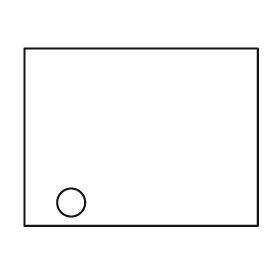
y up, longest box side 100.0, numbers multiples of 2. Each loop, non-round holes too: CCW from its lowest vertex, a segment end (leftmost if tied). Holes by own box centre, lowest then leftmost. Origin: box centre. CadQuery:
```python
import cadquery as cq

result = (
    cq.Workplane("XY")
    .moveTo(-50.0, -38.0)
    .lineTo(50.0, -38.0)
    .lineTo(50.0, 38.0)
    .lineTo(-50.0, 38.0)
    .close()
    .moveTo(-30.0, -28.0)
    .circle(6.0)
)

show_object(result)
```